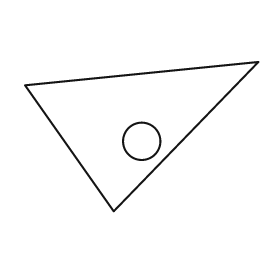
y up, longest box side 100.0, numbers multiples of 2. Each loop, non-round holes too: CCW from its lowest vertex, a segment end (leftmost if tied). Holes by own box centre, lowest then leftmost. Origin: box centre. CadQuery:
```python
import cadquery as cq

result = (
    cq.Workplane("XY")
    .moveTo(-12.0, -32.0)
    .lineTo(50.0, 32.0)
    .lineTo(-50.0, 22.0)
    .close()
    .moveTo(0.0, -2.0)
    .circle(8.0)
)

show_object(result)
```